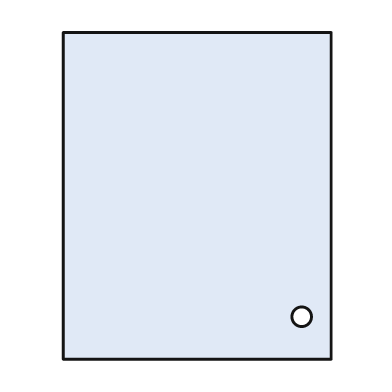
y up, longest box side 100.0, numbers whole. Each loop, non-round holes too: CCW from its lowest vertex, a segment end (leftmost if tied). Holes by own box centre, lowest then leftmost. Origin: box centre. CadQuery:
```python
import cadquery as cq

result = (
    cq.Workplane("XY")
    .moveTo(-41.0, -50.0)
    .lineTo(41.0, -50.0)
    .lineTo(41.0, 50.0)
    .lineTo(-41.0, 50.0)
    .close()
    .moveTo(32.0, -37.0)
    .circle(3.0)
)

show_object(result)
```